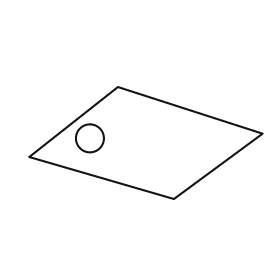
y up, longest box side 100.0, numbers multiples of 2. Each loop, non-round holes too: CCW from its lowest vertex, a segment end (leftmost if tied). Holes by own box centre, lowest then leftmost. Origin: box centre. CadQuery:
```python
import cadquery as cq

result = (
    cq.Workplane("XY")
    .moveTo(12.0, -24.0)
    .lineTo(50.0, 4.0)
    .lineTo(-12.0, 24.0)
    .lineTo(-50.0, -6.0)
    .close()
    .moveTo(-24.0, 2.0)
    .circle(6.0)
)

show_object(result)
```